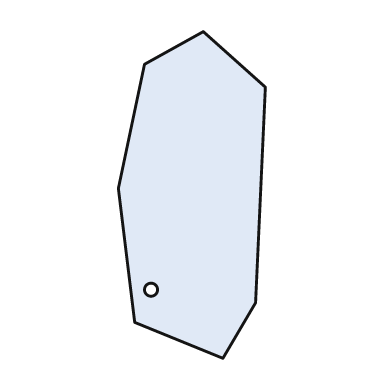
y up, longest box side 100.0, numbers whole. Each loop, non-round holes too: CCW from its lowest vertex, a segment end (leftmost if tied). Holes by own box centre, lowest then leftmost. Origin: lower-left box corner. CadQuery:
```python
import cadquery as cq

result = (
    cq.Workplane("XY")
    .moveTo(32.0, 0.0)
    .lineTo(42.0, 17.0)
    .lineTo(45.0, 83.0)
    .lineTo(26.0, 100.0)
    .lineTo(8.0, 90.0)
    .lineTo(0.0, 52.0)
    .lineTo(5.0, 11.0)
    .close()
    .moveTo(10.0, 21.0)
    .circle(2.0)
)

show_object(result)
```